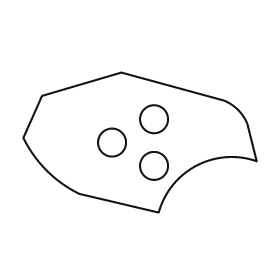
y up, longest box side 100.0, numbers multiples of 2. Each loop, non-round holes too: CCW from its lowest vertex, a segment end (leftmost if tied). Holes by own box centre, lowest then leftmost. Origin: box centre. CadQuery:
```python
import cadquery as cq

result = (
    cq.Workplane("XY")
    .moveTo(8.0, -30.0)
    .threePointArc((24.0, -10.0), (50.0, -8.0))
    .lineTo(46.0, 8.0)
    .threePointArc((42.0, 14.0), (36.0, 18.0))
    .lineTo(-8.0, 30.0)
    .lineTo(-42.0, 20.0)
    .lineTo(-50.0, 2.0)
    .threePointArc((-40.0, -12.0), (-26.0, -22.0))
    .close()
    .moveTo(6.0, -10.0)
    .circle(6.0)
    .moveTo(-12.0, 0.0)
    .circle(6.0)
    .moveTo(6.0, 10.0)
    .circle(6.0)
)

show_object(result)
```